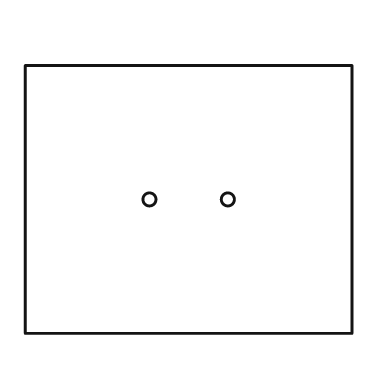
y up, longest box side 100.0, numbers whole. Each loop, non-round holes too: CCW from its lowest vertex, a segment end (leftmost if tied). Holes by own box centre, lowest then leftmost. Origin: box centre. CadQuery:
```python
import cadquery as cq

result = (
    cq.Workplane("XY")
    .moveTo(-50.0, -41.0)
    .lineTo(50.0, -41.0)
    .lineTo(50.0, 41.0)
    .lineTo(-50.0, 41.0)
    .close()
    .moveTo(-12.0, 0.0)
    .circle(2.0)
    .moveTo(12.0, 0.0)
    .circle(2.0)
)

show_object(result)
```